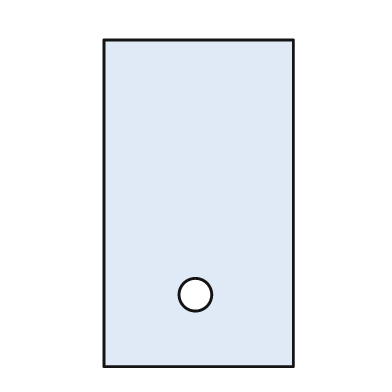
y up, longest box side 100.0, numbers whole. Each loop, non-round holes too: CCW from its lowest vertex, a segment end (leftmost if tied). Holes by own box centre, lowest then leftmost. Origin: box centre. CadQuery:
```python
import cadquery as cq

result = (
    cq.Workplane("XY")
    .moveTo(-29.0, -50.0)
    .lineTo(29.0, -50.0)
    .lineTo(29.0, 50.0)
    .lineTo(-29.0, 50.0)
    .close()
    .moveTo(-1.0, -28.0)
    .circle(5.0)
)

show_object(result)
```